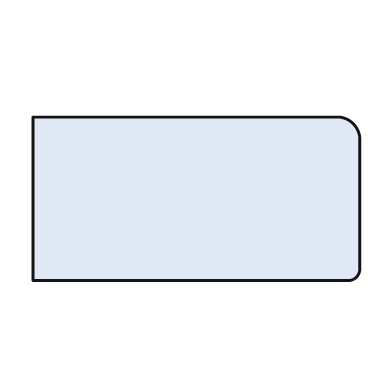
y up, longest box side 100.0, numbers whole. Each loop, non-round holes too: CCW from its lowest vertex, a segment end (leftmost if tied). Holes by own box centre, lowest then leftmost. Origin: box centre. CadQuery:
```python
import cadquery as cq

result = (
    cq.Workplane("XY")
    .moveTo(-50.0, -25.0)
    .lineTo(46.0, -25.0)
    .threePointArc((49.0, -24.0), (50.0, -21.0))
    .lineTo(50.0, 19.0)
    .threePointArc((48.0, 23.0), (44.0, 25.0))
    .lineTo(-50.0, 25.0)
    .close()
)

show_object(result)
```